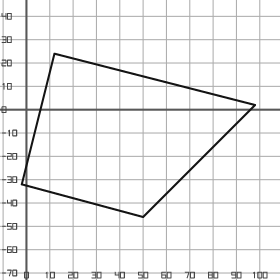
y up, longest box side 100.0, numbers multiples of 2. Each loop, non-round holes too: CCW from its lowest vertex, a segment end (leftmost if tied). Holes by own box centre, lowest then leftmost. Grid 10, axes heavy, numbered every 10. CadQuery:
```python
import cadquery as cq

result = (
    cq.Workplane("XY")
    .moveTo(50.0, -46.0)
    .lineTo(98.0, 2.0)
    .lineTo(12.0, 24.0)
    .lineTo(-2.0, -32.0)
    .close()
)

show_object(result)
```